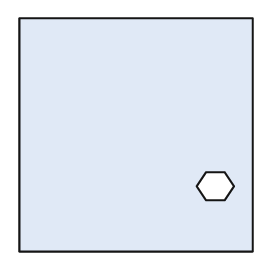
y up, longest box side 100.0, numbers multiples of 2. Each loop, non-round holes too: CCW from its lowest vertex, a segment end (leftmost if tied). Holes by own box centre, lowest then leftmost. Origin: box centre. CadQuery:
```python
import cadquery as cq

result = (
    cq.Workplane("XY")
    .moveTo(-50.0, -50.0)
    .lineTo(50.0, -50.0)
    .lineTo(50.0, 50.0)
    .lineTo(-50.0, 50.0)
    .close()
    .moveTo(30.0, -28.0)
    .lineTo(38.0, -28.0)
    .lineTo(42.0, -22.0)
    .lineTo(38.0, -16.0)
    .lineTo(30.0, -16.0)
    .lineTo(26.0, -22.0)
    .close()
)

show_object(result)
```